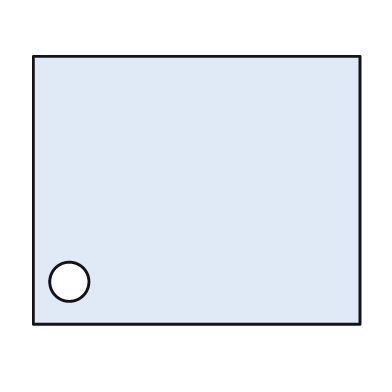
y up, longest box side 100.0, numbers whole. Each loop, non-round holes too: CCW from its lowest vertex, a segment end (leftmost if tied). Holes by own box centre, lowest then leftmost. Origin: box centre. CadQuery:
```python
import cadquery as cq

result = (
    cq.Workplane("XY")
    .moveTo(-50.0, -41.0)
    .lineTo(50.0, -41.0)
    .lineTo(50.0, 41.0)
    .lineTo(-50.0, 41.0)
    .close()
    .moveTo(-39.0, -28.0)
    .circle(6.0)
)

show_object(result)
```